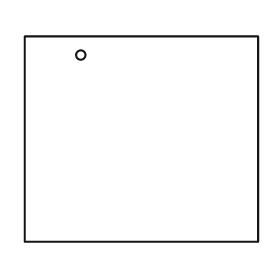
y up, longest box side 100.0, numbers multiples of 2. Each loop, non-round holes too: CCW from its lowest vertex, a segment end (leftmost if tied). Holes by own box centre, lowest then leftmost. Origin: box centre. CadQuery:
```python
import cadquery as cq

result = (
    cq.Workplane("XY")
    .moveTo(-50.0, -44.0)
    .lineTo(50.0, -44.0)
    .lineTo(50.0, 44.0)
    .lineTo(-50.0, 44.0)
    .close()
    .moveTo(-26.0, 36.0)
    .circle(2.0)
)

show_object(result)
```